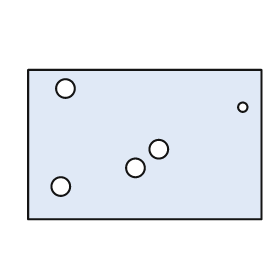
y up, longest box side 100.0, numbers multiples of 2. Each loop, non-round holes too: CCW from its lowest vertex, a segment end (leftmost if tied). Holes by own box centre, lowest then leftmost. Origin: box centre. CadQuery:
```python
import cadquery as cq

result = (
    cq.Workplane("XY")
    .moveTo(-50.0, -32.0)
    .lineTo(50.0, -32.0)
    .lineTo(50.0, 32.0)
    .lineTo(-50.0, 32.0)
    .close()
    .moveTo(-36.0, -18.0)
    .circle(4.0)
    .moveTo(-4.0, -10.0)
    .circle(4.0)
    .moveTo(6.0, -2.0)
    .circle(4.0)
    .moveTo(42.0, 16.0)
    .circle(2.0)
    .moveTo(-34.0, 24.0)
    .circle(4.0)
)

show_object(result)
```